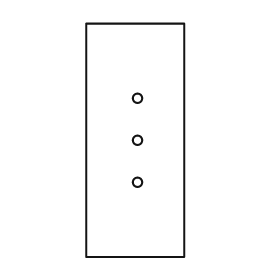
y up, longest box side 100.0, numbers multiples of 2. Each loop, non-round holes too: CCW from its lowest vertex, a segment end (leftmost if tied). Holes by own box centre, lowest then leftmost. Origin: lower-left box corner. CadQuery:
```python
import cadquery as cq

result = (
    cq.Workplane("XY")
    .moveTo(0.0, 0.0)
    .lineTo(42.0, 0.0)
    .lineTo(42.0, 100.0)
    .lineTo(0.0, 100.0)
    .close()
    .moveTo(22.0, 32.0)
    .circle(2.0)
    .moveTo(22.0, 50.0)
    .circle(2.0)
    .moveTo(22.0, 68.0)
    .circle(2.0)
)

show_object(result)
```